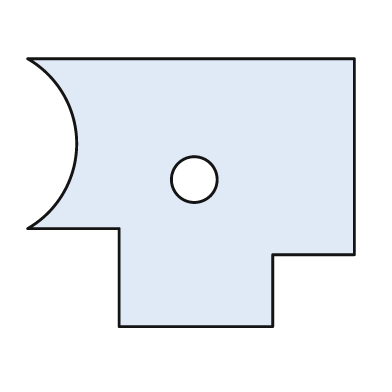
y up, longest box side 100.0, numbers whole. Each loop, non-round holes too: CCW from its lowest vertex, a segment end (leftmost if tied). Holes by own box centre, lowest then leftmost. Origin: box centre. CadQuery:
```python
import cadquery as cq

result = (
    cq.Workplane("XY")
    .moveTo(-22.0, -41.0)
    .lineTo(25.0, -41.0)
    .lineTo(25.0, -19.0)
    .lineTo(50.0, -19.0)
    .lineTo(50.0, 41.0)
    .lineTo(-50.0, 41.0)
    .threePointArc((-35.0, 15.0), (-50.0, -11.0))
    .lineTo(-22.0, -11.0)
    .close()
    .moveTo(1.0, 4.0)
    .circle(7.0)
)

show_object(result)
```